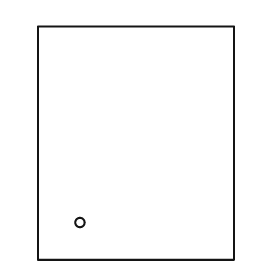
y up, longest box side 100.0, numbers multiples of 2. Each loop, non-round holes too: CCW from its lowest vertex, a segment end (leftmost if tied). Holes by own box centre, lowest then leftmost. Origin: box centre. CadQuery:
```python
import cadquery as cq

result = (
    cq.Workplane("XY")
    .moveTo(-42.0, -50.0)
    .lineTo(42.0, -50.0)
    .lineTo(42.0, 50.0)
    .lineTo(-42.0, 50.0)
    .close()
    .moveTo(-24.0, -34.0)
    .circle(2.0)
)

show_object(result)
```